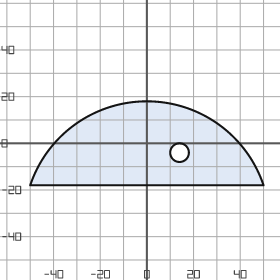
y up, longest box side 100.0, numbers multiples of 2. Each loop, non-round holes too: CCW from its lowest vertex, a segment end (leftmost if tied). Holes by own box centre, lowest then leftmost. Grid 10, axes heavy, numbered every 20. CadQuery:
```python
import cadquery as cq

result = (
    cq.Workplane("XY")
    .moveTo(-50.0, -18.0)
    .lineTo(50.0, -18.0)
    .threePointArc((0.0, 18.0), (-50.0, -18.0))
    .close()
    .moveTo(14.0, -4.0)
    .circle(4.0)
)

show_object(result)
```